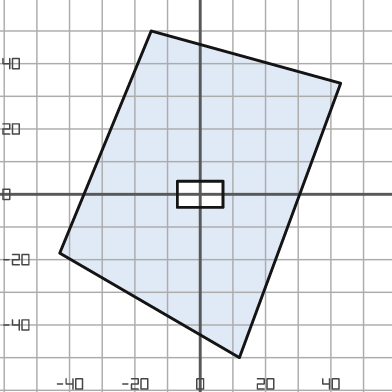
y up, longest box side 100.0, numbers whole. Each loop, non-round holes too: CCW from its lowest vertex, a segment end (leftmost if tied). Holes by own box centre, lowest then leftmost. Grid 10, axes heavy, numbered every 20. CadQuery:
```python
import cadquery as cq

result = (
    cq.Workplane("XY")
    .moveTo(12.0, -50.0)
    .lineTo(43.0, 34.0)
    .lineTo(-15.0, 50.0)
    .lineTo(-43.0, -18.0)
    .close()
    .moveTo(-7.0, -4.0)
    .lineTo(7.0, -4.0)
    .lineTo(7.0, 4.0)
    .lineTo(-7.0, 4.0)
    .close()
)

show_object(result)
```